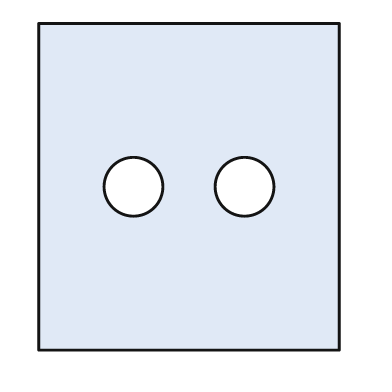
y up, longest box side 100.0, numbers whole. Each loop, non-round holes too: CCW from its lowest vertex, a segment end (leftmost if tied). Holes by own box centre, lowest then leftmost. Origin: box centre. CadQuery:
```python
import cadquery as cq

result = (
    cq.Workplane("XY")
    .moveTo(-46.0, -50.0)
    .lineTo(46.0, -50.0)
    .lineTo(46.0, 50.0)
    .lineTo(-46.0, 50.0)
    .close()
    .moveTo(-17.0, 0.0)
    .circle(9.0)
    .moveTo(17.0, 0.0)
    .circle(9.0)
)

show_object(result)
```